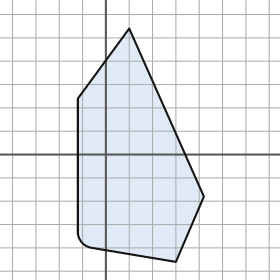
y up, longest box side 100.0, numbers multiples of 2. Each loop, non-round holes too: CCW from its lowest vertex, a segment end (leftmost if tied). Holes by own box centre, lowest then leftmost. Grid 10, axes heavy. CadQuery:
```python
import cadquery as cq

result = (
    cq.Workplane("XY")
    .moveTo(30.0, -46.0)
    .lineTo(42.0, -18.0)
    .lineTo(10.0, 54.0)
    .lineTo(-12.0, 24.0)
    .lineTo(-12.0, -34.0)
    .threePointArc((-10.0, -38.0), (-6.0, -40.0))
    .close()
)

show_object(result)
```